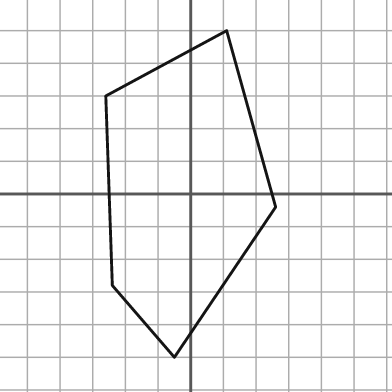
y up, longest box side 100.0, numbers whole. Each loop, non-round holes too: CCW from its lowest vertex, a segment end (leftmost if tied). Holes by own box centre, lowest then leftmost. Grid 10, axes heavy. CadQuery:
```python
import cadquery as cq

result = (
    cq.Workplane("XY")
    .moveTo(-5.0, -50.0)
    .lineTo(26.0, -4.0)
    .lineTo(11.0, 50.0)
    .lineTo(-26.0, 30.0)
    .lineTo(-24.0, -28.0)
    .close()
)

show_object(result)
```